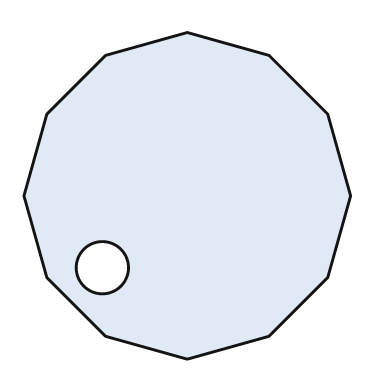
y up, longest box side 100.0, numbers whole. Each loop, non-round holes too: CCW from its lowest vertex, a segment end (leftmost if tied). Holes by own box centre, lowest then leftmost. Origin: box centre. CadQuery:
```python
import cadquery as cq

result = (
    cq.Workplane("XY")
    .moveTo(0.0, -50.0)
    .lineTo(25.0, -43.0)
    .lineTo(43.0, -25.0)
    .lineTo(50.0, 0.0)
    .lineTo(43.0, 25.0)
    .lineTo(25.0, 43.0)
    .lineTo(0.0, 50.0)
    .lineTo(-25.0, 43.0)
    .lineTo(-43.0, 25.0)
    .lineTo(-50.0, 0.0)
    .lineTo(-43.0, -25.0)
    .lineTo(-25.0, -43.0)
    .close()
    .moveTo(-26.0, -22.0)
    .circle(8.0)
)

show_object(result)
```